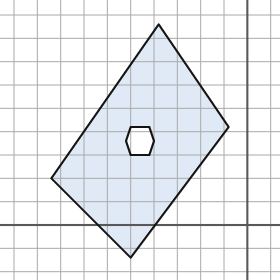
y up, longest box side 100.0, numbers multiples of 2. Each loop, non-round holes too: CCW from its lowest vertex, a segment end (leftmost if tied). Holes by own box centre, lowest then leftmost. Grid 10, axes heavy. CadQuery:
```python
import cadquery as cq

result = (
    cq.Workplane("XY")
    .moveTo(-50.0, -14.0)
    .lineTo(-8.0, 42.0)
    .lineTo(-38.0, 86.0)
    .lineTo(-84.0, 20.0)
    .close()
    .moveTo(-50.0, 30.0)
    .lineTo(-42.0, 30.0)
    .lineTo(-40.0, 36.0)
    .lineTo(-42.0, 42.0)
    .lineTo(-50.0, 42.0)
    .lineTo(-52.0, 36.0)
    .close()
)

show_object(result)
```